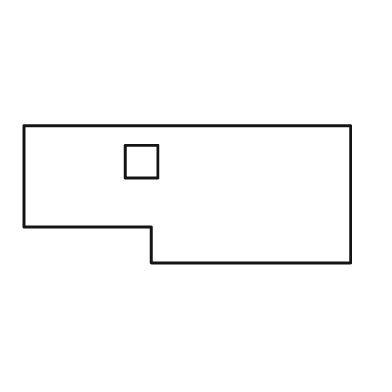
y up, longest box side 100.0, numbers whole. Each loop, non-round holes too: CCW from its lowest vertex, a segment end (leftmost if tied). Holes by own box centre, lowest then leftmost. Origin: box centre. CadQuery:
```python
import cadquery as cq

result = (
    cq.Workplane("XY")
    .moveTo(-11.0, -21.0)
    .lineTo(50.0, -21.0)
    .lineTo(50.0, 21.0)
    .lineTo(-50.0, 21.0)
    .lineTo(-50.0, -10.0)
    .lineTo(-11.0, -10.0)
    .close()
    .moveTo(-19.0, 5.0)
    .lineTo(-9.0, 5.0)
    .lineTo(-9.0, 15.0)
    .lineTo(-19.0, 15.0)
    .close()
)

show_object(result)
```